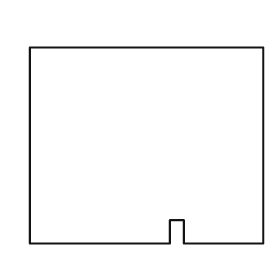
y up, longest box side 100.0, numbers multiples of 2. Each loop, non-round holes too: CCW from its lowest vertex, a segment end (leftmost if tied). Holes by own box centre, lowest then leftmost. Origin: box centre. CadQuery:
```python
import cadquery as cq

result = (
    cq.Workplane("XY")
    .moveTo(-50.0, -42.0)
    .lineTo(10.0, -42.0)
    .lineTo(10.0, -32.0)
    .lineTo(16.0, -32.0)
    .lineTo(16.0, -42.0)
    .lineTo(50.0, -42.0)
    .lineTo(50.0, 42.0)
    .lineTo(-50.0, 42.0)
    .close()
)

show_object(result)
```